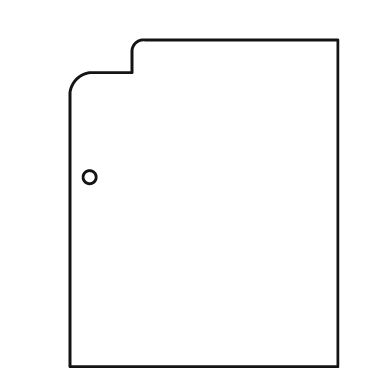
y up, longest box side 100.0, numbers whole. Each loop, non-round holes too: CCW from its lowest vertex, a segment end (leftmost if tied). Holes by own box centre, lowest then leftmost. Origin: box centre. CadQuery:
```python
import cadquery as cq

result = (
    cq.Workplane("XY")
    .moveTo(-41.0, -50.0)
    .lineTo(41.0, -50.0)
    .lineTo(41.0, 50.0)
    .lineTo(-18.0, 50.0)
    .threePointArc((-21.0, 49.0), (-22.0, 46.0))
    .lineTo(-22.0, 40.0)
    .lineTo(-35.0, 40.0)
    .threePointArc((-39.0, 38.0), (-41.0, 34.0))
    .close()
    .moveTo(-35.0, 8.0)
    .circle(2.0)
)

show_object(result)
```